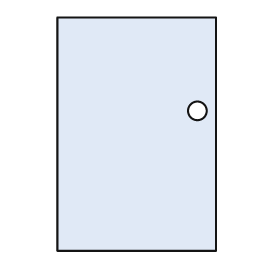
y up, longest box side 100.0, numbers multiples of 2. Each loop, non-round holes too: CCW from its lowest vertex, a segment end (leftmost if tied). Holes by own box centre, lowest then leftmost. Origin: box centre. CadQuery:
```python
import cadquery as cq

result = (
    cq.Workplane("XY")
    .moveTo(-34.0, -50.0)
    .lineTo(34.0, -50.0)
    .lineTo(34.0, 50.0)
    .lineTo(-34.0, 50.0)
    .close()
    .moveTo(26.0, 10.0)
    .circle(4.0)
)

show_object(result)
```